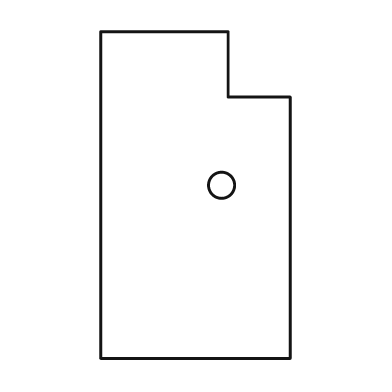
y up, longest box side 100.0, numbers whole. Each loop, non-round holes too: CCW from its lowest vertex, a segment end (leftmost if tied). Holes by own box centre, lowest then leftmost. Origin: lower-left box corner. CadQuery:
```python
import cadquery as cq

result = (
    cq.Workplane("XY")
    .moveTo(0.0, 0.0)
    .lineTo(58.0, 0.0)
    .lineTo(58.0, 80.0)
    .lineTo(39.0, 80.0)
    .lineTo(39.0, 100.0)
    .lineTo(0.0, 100.0)
    .close()
    .moveTo(37.0, 53.0)
    .circle(4.0)
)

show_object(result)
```